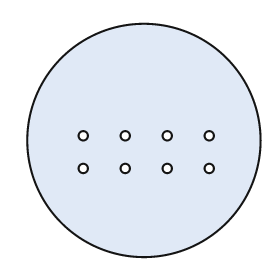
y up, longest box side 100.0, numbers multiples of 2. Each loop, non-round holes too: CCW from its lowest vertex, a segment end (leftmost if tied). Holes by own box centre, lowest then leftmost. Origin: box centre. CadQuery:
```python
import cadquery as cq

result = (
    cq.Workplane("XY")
    .moveTo(0.0, 0.0)
    .circle(50.0)
    .moveTo(-26.0, -12.0)
    .circle(2.0)
    .moveTo(-8.0, -12.0)
    .circle(2.0)
    .moveTo(10.0, -12.0)
    .circle(2.0)
    .moveTo(28.0, -12.0)
    .circle(2.0)
    .moveTo(-26.0, 2.0)
    .circle(2.0)
    .moveTo(-8.0, 2.0)
    .circle(2.0)
    .moveTo(10.0, 2.0)
    .circle(2.0)
    .moveTo(28.0, 2.0)
    .circle(2.0)
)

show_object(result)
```